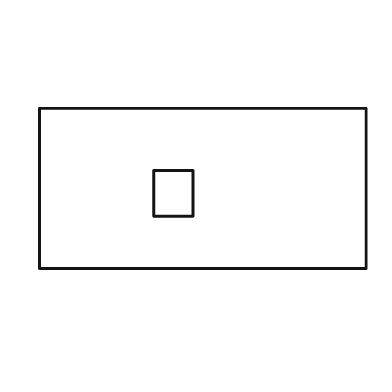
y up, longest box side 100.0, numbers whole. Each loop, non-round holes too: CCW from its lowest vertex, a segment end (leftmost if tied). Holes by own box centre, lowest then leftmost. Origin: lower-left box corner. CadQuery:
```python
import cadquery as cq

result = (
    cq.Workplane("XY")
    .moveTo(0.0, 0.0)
    .lineTo(100.0, 0.0)
    .lineTo(100.0, 49.0)
    .lineTo(0.0, 49.0)
    .close()
    .moveTo(35.0, 16.0)
    .lineTo(47.0, 16.0)
    .lineTo(47.0, 30.0)
    .lineTo(35.0, 30.0)
    .close()
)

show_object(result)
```